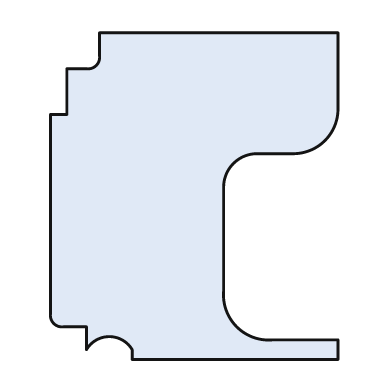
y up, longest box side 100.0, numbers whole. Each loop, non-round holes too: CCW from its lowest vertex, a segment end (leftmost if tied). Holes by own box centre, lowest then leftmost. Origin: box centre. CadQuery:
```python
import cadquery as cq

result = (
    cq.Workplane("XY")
    .moveTo(-19.0, -50.0)
    .lineTo(44.0, -50.0)
    .lineTo(44.0, -44.0)
    .lineTo(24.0, -44.0)
    .threePointArc((13.0, -40.0), (9.0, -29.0))
    .lineTo(9.0, 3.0)
    .threePointArc((12.0, 10.0), (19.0, 13.0))
    .lineTo(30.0, 13.0)
    .threePointArc((40.0, 17.0), (44.0, 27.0))
    .lineTo(44.0, 50.0)
    .lineTo(-29.0, 50.0)
    .lineTo(-29.0, 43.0)
    .threePointArc((-30.0, 40.0), (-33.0, 39.0))
    .lineTo(-39.0, 39.0)
    .lineTo(-39.0, 25.0)
    .lineTo(-44.0, 25.0)
    .lineTo(-44.0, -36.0)
    .threePointArc((-43.0, -39.0), (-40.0, -40.0))
    .lineTo(-33.0, -40.0)
    .lineTo(-33.0, -47.0)
    .threePointArc((-26.0, -43.0), (-19.0, -47.0))
    .close()
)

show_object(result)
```